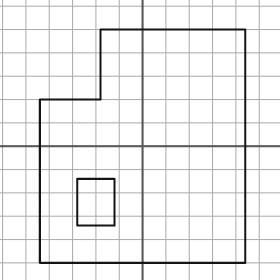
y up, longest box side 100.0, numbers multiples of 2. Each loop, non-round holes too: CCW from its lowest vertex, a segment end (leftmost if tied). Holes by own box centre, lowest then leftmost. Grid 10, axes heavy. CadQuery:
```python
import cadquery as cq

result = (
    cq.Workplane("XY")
    .moveTo(-44.0, -50.0)
    .lineTo(44.0, -50.0)
    .lineTo(44.0, 50.0)
    .lineTo(-18.0, 50.0)
    .lineTo(-18.0, 20.0)
    .lineTo(-44.0, 20.0)
    .close()
    .moveTo(-28.0, -34.0)
    .lineTo(-12.0, -34.0)
    .lineTo(-12.0, -14.0)
    .lineTo(-28.0, -14.0)
    .close()
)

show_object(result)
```